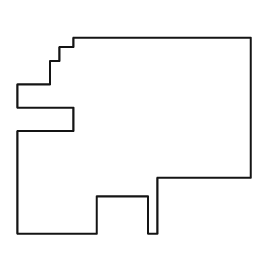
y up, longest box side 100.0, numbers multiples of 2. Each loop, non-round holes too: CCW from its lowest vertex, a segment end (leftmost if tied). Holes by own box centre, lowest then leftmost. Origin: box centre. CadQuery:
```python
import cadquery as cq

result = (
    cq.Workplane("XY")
    .moveTo(-50.0, -42.0)
    .lineTo(-16.0, -42.0)
    .lineTo(-16.0, -26.0)
    .lineTo(6.0, -26.0)
    .lineTo(6.0, -42.0)
    .lineTo(10.0, -42.0)
    .lineTo(10.0, -18.0)
    .lineTo(50.0, -18.0)
    .lineTo(50.0, 42.0)
    .lineTo(-26.0, 42.0)
    .lineTo(-26.0, 38.0)
    .lineTo(-32.0, 38.0)
    .lineTo(-32.0, 32.0)
    .lineTo(-36.0, 32.0)
    .lineTo(-36.0, 22.0)
    .lineTo(-50.0, 22.0)
    .lineTo(-50.0, 12.0)
    .lineTo(-26.0, 12.0)
    .lineTo(-26.0, 2.0)
    .lineTo(-50.0, 2.0)
    .close()
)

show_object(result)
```